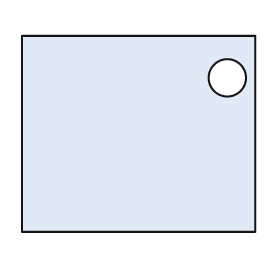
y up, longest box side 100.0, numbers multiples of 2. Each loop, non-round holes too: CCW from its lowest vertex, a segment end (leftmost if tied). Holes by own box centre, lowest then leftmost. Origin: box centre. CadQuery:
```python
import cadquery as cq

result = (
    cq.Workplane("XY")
    .moveTo(-50.0, -42.0)
    .lineTo(50.0, -42.0)
    .lineTo(50.0, 42.0)
    .lineTo(-50.0, 42.0)
    .close()
    .moveTo(38.0, 24.0)
    .circle(8.0)
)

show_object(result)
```